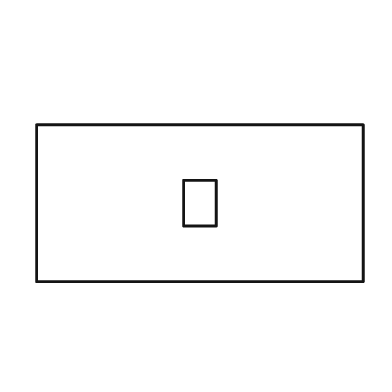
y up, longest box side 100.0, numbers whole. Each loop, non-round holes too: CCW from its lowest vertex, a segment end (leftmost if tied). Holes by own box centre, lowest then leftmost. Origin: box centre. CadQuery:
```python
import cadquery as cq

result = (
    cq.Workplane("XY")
    .moveTo(-50.0, -24.0)
    .lineTo(50.0, -24.0)
    .lineTo(50.0, 24.0)
    .lineTo(-50.0, 24.0)
    .close()
    .moveTo(-5.0, -7.0)
    .lineTo(5.0, -7.0)
    .lineTo(5.0, 7.0)
    .lineTo(-5.0, 7.0)
    .close()
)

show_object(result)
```